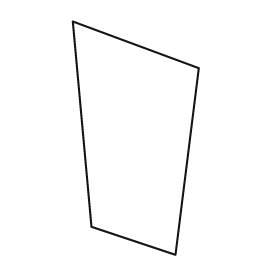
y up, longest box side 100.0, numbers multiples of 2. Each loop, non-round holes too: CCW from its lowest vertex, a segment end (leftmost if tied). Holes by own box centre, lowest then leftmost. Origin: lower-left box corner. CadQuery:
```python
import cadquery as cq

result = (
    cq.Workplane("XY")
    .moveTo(44.0, 0.0)
    .lineTo(54.0, 80.0)
    .lineTo(0.0, 100.0)
    .lineTo(8.0, 12.0)
    .close()
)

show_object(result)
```